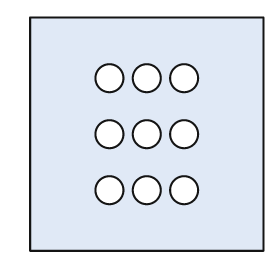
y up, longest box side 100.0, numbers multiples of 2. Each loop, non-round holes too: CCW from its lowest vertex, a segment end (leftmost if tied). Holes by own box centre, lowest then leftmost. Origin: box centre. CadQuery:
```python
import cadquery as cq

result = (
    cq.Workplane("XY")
    .moveTo(-50.0, -50.0)
    .lineTo(50.0, -50.0)
    .lineTo(50.0, 50.0)
    .lineTo(-50.0, 50.0)
    .close()
    .moveTo(-16.0, -24.0)
    .circle(6.0)
    .moveTo(0.0, -24.0)
    .circle(6.0)
    .moveTo(16.0, -24.0)
    .circle(6.0)
    .moveTo(-16.0, 0.0)
    .circle(6.0)
    .moveTo(0.0, 0.0)
    .circle(6.0)
    .moveTo(16.0, 0.0)
    .circle(6.0)
    .moveTo(-16.0, 24.0)
    .circle(6.0)
    .moveTo(0.0, 24.0)
    .circle(6.0)
    .moveTo(16.0, 24.0)
    .circle(6.0)
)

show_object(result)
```